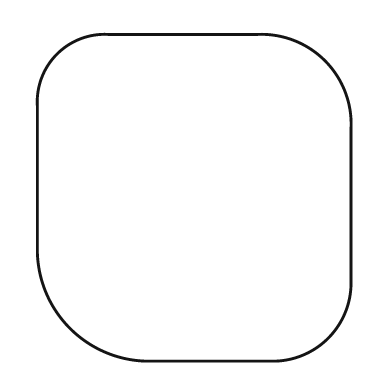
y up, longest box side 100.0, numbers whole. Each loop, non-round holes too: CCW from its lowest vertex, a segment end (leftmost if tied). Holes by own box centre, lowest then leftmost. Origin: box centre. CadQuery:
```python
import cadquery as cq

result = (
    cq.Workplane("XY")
    .moveTo(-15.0, -50.0)
    .lineTo(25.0, -50.0)
    .threePointArc((41.0, -43.0), (48.0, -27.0))
    .lineTo(48.0, 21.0)
    .threePointArc((40.0, 42.0), (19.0, 50.0))
    .lineTo(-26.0, 50.0)
    .threePointArc((-42.0, 44.0), (-48.0, 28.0))
    .lineTo(-48.0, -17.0)
    .threePointArc((-38.0, -40.0), (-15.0, -50.0))
    .close()
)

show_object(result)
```